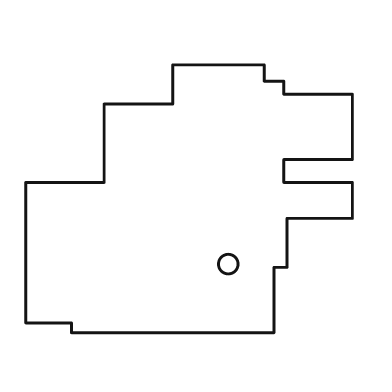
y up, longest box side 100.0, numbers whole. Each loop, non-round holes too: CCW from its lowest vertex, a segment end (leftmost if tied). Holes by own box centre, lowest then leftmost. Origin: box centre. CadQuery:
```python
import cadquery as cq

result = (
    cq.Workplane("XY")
    .moveTo(-36.0, -41.0)
    .lineTo(26.0, -41.0)
    .lineTo(26.0, -21.0)
    .lineTo(30.0, -21.0)
    .lineTo(30.0, -6.0)
    .lineTo(50.0, -6.0)
    .lineTo(50.0, 5.0)
    .lineTo(29.0, 5.0)
    .lineTo(29.0, 12.0)
    .lineTo(50.0, 12.0)
    .lineTo(50.0, 32.0)
    .lineTo(29.0, 32.0)
    .lineTo(29.0, 36.0)
    .lineTo(23.0, 36.0)
    .lineTo(23.0, 41.0)
    .lineTo(-5.0, 41.0)
    .lineTo(-5.0, 29.0)
    .lineTo(-26.0, 29.0)
    .lineTo(-26.0, 5.0)
    .lineTo(-50.0, 5.0)
    .lineTo(-50.0, -38.0)
    .lineTo(-36.0, -38.0)
    .close()
    .moveTo(12.0, -20.0)
    .circle(3.0)
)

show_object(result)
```